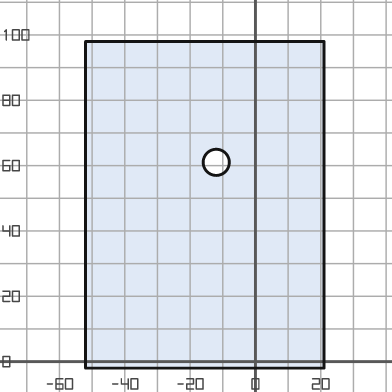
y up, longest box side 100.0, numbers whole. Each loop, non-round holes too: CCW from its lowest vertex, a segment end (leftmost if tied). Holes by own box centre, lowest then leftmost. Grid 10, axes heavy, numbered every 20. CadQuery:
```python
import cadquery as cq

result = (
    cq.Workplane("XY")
    .moveTo(-52.0, -2.0)
    .lineTo(21.0, -2.0)
    .lineTo(21.0, 98.0)
    .lineTo(-52.0, 98.0)
    .close()
    .moveTo(-12.0, 61.0)
    .circle(4.0)
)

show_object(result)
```